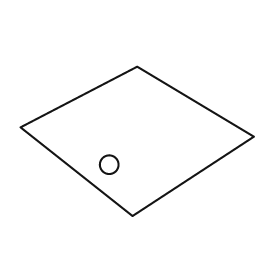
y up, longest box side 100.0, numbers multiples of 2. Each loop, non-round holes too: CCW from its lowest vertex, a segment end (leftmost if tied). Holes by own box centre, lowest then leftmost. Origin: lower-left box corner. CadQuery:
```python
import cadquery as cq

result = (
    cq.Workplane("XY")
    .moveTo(48.0, 0.0)
    .lineTo(100.0, 34.0)
    .lineTo(50.0, 64.0)
    .lineTo(0.0, 38.0)
    .close()
    .moveTo(38.0, 22.0)
    .circle(4.0)
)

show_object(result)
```